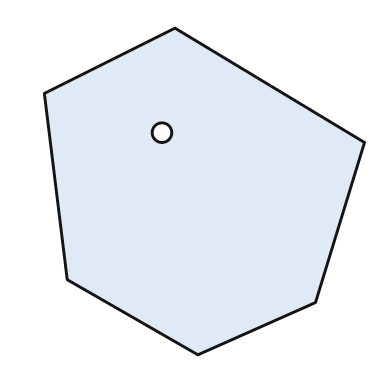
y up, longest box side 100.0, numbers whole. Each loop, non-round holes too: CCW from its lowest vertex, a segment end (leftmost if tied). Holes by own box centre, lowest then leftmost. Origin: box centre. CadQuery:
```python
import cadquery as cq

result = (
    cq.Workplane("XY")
    .moveTo(-2.0, -50.0)
    .lineTo(34.0, -34.0)
    .lineTo(49.0, 15.0)
    .lineTo(-9.0, 50.0)
    .lineTo(-49.0, 30.0)
    .lineTo(-42.0, -27.0)
    .close()
    .moveTo(-13.0, 18.0)
    .circle(3.0)
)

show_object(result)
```